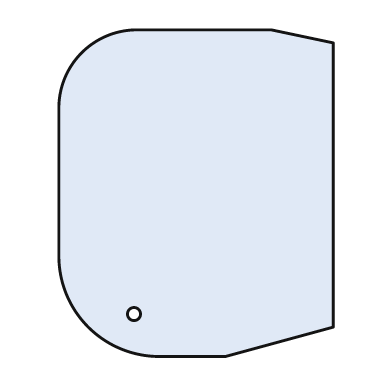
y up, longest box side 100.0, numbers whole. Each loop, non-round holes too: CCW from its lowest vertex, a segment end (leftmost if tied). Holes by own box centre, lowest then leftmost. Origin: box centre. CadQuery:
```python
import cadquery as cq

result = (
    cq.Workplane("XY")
    .moveTo(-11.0, -50.0)
    .lineTo(9.0, -50.0)
    .lineTo(42.0, -41.0)
    .lineTo(42.0, 46.0)
    .lineTo(23.0, 50.0)
    .lineTo(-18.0, 50.0)
    .threePointArc((-35.0, 43.0), (-42.0, 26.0))
    .lineTo(-42.0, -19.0)
    .threePointArc((-33.0, -41.0), (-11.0, -50.0))
    .close()
    .moveTo(-19.0, -37.0)
    .circle(2.0)
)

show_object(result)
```